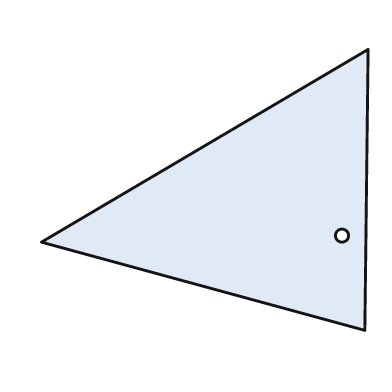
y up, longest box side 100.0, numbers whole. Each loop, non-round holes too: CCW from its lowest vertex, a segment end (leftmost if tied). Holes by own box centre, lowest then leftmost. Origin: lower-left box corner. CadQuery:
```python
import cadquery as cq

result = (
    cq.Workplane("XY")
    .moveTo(99.0, 0.0)
    .lineTo(100.0, 86.0)
    .lineTo(0.0, 27.0)
    .close()
    .moveTo(92.0, 29.0)
    .circle(2.0)
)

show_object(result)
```